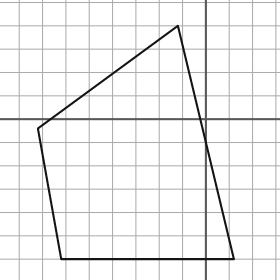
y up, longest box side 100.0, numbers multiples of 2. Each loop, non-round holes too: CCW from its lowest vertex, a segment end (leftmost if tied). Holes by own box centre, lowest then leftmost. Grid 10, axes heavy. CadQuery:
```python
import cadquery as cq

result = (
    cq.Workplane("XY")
    .moveTo(-62.0, -60.0)
    .lineTo(12.0, -60.0)
    .lineTo(-12.0, 40.0)
    .lineTo(-72.0, -4.0)
    .close()
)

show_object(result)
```